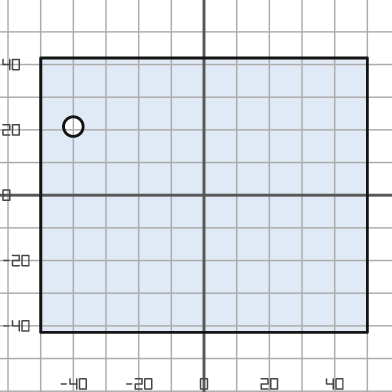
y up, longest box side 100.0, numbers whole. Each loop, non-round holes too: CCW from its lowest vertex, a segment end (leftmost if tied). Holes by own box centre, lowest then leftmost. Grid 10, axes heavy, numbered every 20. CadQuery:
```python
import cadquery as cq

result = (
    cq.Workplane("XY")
    .moveTo(-50.0, -42.0)
    .lineTo(50.0, -42.0)
    .lineTo(50.0, 42.0)
    .lineTo(-50.0, 42.0)
    .close()
    .moveTo(-40.0, 21.0)
    .circle(3.0)
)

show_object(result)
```